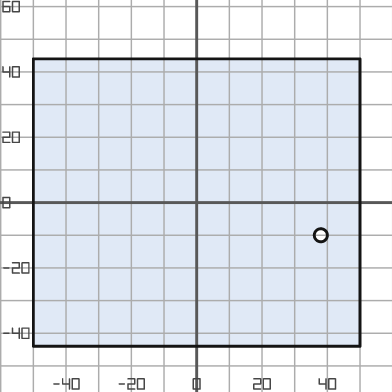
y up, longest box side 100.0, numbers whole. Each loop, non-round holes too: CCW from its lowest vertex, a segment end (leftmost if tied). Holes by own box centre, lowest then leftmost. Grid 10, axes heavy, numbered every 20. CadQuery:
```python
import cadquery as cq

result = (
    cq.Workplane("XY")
    .moveTo(-50.0, -44.0)
    .lineTo(50.0, -44.0)
    .lineTo(50.0, 44.0)
    .lineTo(-50.0, 44.0)
    .close()
    .moveTo(38.0, -10.0)
    .circle(2.0)
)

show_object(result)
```